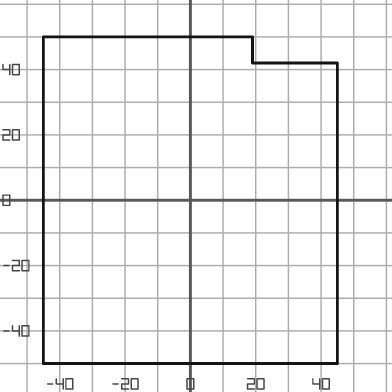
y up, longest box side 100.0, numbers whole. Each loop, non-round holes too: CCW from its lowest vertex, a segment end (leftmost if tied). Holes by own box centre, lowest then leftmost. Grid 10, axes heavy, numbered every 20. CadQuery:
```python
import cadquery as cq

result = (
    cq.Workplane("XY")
    .moveTo(-45.0, -50.0)
    .lineTo(45.0, -50.0)
    .lineTo(45.0, 42.0)
    .lineTo(19.0, 42.0)
    .lineTo(19.0, 50.0)
    .lineTo(-45.0, 50.0)
    .close()
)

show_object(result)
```